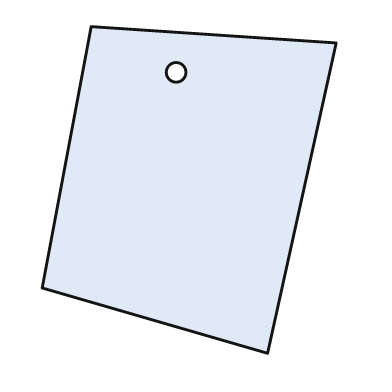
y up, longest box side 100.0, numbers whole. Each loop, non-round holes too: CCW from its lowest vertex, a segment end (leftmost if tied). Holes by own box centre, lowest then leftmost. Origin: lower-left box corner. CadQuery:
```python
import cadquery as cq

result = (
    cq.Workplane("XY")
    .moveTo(69.0, 0.0)
    .lineTo(90.0, 95.0)
    .lineTo(15.0, 100.0)
    .lineTo(0.0, 20.0)
    .close()
    .moveTo(41.0, 86.0)
    .circle(3.0)
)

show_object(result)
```